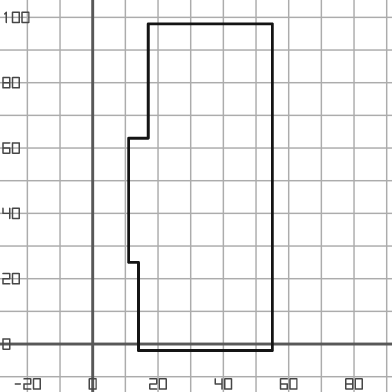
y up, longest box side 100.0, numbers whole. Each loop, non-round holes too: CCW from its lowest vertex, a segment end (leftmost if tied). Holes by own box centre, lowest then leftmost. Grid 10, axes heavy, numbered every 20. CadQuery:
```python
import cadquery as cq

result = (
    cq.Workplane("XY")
    .moveTo(14.0, -2.0)
    .lineTo(55.0, -2.0)
    .lineTo(55.0, 98.0)
    .lineTo(17.0, 98.0)
    .lineTo(17.0, 63.0)
    .lineTo(11.0, 63.0)
    .lineTo(11.0, 25.0)
    .lineTo(14.0, 25.0)
    .close()
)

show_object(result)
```